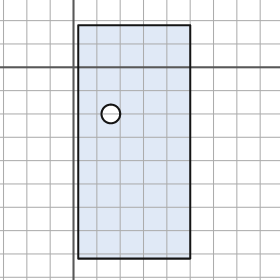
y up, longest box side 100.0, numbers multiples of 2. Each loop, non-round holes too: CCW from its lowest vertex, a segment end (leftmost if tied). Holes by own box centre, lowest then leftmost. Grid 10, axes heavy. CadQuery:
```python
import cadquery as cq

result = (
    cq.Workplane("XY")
    .moveTo(2.0, -82.0)
    .lineTo(50.0, -82.0)
    .lineTo(50.0, 18.0)
    .lineTo(2.0, 18.0)
    .close()
    .moveTo(16.0, -20.0)
    .circle(4.0)
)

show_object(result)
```